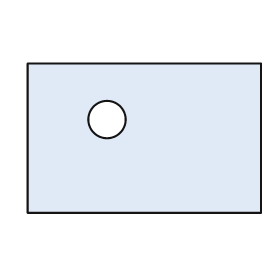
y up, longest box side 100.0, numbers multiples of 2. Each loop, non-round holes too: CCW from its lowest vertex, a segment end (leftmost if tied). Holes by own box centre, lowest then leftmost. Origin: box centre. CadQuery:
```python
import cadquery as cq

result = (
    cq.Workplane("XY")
    .moveTo(-50.0, -32.0)
    .lineTo(50.0, -32.0)
    .lineTo(50.0, 32.0)
    .lineTo(-50.0, 32.0)
    .close()
    .moveTo(-16.0, 8.0)
    .circle(8.0)
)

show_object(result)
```